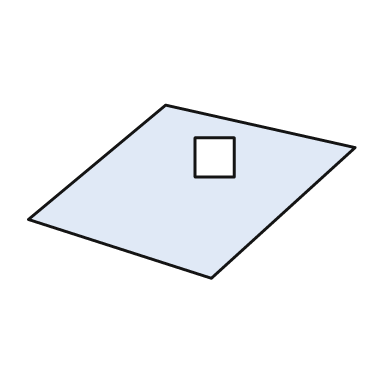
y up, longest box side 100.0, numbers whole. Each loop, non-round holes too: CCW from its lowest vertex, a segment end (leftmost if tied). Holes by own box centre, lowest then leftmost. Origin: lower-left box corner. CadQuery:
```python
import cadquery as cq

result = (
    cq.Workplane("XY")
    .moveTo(56.0, 0.0)
    .lineTo(100.0, 40.0)
    .lineTo(42.0, 53.0)
    .lineTo(0.0, 18.0)
    .close()
    .moveTo(51.0, 31.0)
    .lineTo(63.0, 31.0)
    .lineTo(63.0, 43.0)
    .lineTo(51.0, 43.0)
    .close()
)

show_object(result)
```